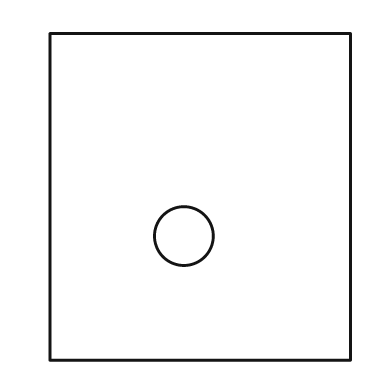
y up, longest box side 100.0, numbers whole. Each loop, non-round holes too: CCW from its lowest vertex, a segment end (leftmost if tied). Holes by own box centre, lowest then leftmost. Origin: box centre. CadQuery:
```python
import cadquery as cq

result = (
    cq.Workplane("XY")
    .moveTo(-46.0, -50.0)
    .lineTo(46.0, -50.0)
    .lineTo(46.0, 50.0)
    .lineTo(-46.0, 50.0)
    .close()
    .moveTo(-5.0, -12.0)
    .circle(9.0)
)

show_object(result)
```